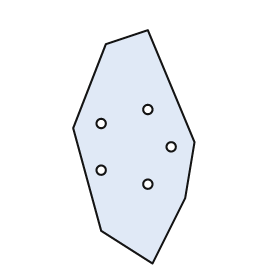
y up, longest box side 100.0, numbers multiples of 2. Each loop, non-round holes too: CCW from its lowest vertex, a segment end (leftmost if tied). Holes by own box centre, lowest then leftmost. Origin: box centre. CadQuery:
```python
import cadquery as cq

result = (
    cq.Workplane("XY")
    .moveTo(8.0, -50.0)
    .lineTo(22.0, -22.0)
    .lineTo(26.0, 2.0)
    .lineTo(6.0, 50.0)
    .lineTo(-12.0, 44.0)
    .lineTo(-26.0, 8.0)
    .lineTo(-14.0, -36.0)
    .close()
    .moveTo(6.0, -16.0)
    .circle(2.0)
    .moveTo(-14.0, -10.0)
    .circle(2.0)
    .moveTo(16.0, 0.0)
    .circle(2.0)
    .moveTo(-14.0, 10.0)
    .circle(2.0)
    .moveTo(6.0, 16.0)
    .circle(2.0)
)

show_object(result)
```